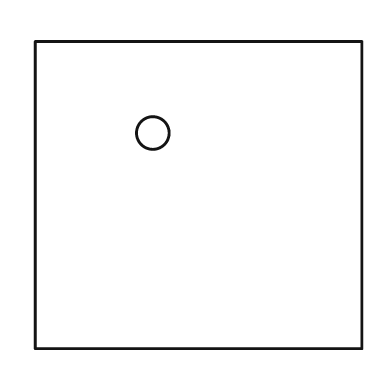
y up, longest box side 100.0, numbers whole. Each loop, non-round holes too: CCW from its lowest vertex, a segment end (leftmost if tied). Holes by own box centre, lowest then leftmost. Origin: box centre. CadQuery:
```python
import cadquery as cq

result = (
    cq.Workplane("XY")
    .moveTo(-50.0, -47.0)
    .lineTo(50.0, -47.0)
    .lineTo(50.0, 47.0)
    .lineTo(-50.0, 47.0)
    .close()
    .moveTo(-14.0, 19.0)
    .circle(5.0)
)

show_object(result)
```